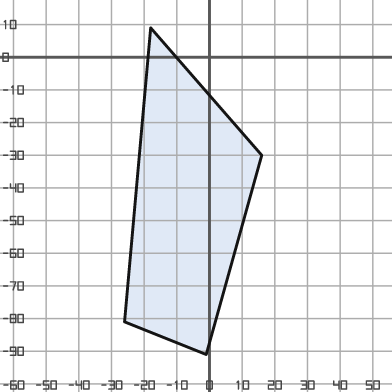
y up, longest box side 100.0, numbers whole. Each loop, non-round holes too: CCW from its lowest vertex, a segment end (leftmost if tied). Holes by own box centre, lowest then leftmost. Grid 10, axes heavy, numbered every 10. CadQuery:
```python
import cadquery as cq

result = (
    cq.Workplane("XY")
    .moveTo(-1.0, -91.0)
    .lineTo(16.0, -30.0)
    .lineTo(-18.0, 9.0)
    .lineTo(-26.0, -81.0)
    .close()
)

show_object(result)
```